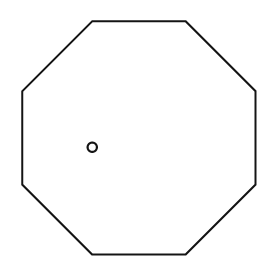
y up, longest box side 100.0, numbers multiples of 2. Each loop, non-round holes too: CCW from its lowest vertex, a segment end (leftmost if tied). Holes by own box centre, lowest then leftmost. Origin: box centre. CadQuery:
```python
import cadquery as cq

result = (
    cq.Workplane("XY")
    .moveTo(-20.0, -50.0)
    .lineTo(20.0, -50.0)
    .lineTo(50.0, -20.0)
    .lineTo(50.0, 20.0)
    .lineTo(20.0, 50.0)
    .lineTo(-20.0, 50.0)
    .lineTo(-50.0, 20.0)
    .lineTo(-50.0, -20.0)
    .close()
    .moveTo(-20.0, -4.0)
    .circle(2.0)
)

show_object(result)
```